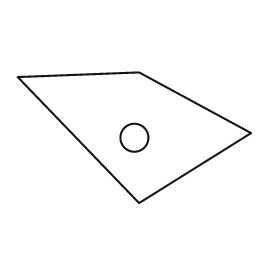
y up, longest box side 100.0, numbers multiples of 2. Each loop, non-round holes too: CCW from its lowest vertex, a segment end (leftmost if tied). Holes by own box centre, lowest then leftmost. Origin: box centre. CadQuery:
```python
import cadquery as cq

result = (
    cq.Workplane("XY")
    .moveTo(2.0, -28.0)
    .lineTo(50.0, 2.0)
    .lineTo(2.0, 28.0)
    .lineTo(-50.0, 26.0)
    .close()
    .moveTo(0.0, 0.0)
    .circle(6.0)
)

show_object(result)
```